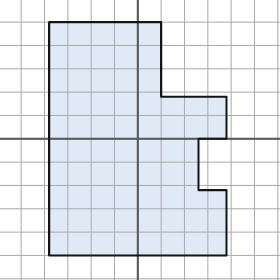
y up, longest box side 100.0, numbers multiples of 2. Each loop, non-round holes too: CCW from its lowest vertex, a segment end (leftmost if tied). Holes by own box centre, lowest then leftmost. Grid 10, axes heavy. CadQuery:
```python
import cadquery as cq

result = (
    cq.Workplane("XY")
    .moveTo(-38.0, -50.0)
    .lineTo(38.0, -50.0)
    .lineTo(38.0, -22.0)
    .lineTo(26.0, -22.0)
    .lineTo(26.0, 0.0)
    .lineTo(38.0, 0.0)
    .lineTo(38.0, 18.0)
    .lineTo(10.0, 18.0)
    .lineTo(10.0, 50.0)
    .lineTo(-38.0, 50.0)
    .close()
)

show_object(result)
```